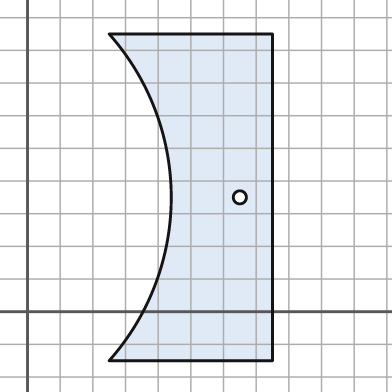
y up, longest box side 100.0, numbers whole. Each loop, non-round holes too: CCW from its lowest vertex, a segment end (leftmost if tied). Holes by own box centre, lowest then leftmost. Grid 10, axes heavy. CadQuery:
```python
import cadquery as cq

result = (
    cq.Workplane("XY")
    .moveTo(25.0, -15.0)
    .lineTo(75.0, -15.0)
    .lineTo(75.0, 85.0)
    .lineTo(25.0, 85.0)
    .threePointArc((44.0, 35.0), (25.0, -15.0))
    .close()
    .moveTo(65.0, 35.0)
    .circle(2.0)
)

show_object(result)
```